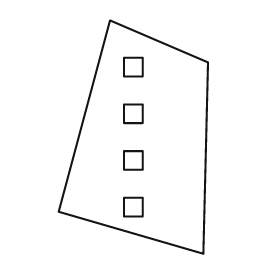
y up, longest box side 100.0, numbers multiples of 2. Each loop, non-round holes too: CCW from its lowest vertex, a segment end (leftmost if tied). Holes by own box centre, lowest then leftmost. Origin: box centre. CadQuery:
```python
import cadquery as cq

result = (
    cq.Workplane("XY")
    .moveTo(30.0, -50.0)
    .lineTo(32.0, 32.0)
    .lineTo(-10.0, 50.0)
    .lineTo(-32.0, -32.0)
    .close()
    .moveTo(-4.0, -34.0)
    .lineTo(4.0, -34.0)
    .lineTo(4.0, -26.0)
    .lineTo(-4.0, -26.0)
    .close()
    .moveTo(-4.0, -14.0)
    .lineTo(4.0, -14.0)
    .lineTo(4.0, -6.0)
    .lineTo(-4.0, -6.0)
    .close()
    .moveTo(-4.0, 6.0)
    .lineTo(4.0, 6.0)
    .lineTo(4.0, 14.0)
    .lineTo(-4.0, 14.0)
    .close()
    .moveTo(-4.0, 26.0)
    .lineTo(4.0, 26.0)
    .lineTo(4.0, 34.0)
    .lineTo(-4.0, 34.0)
    .close()
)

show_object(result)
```